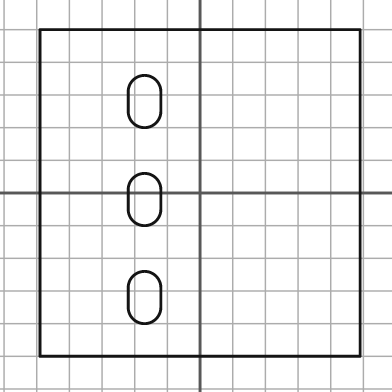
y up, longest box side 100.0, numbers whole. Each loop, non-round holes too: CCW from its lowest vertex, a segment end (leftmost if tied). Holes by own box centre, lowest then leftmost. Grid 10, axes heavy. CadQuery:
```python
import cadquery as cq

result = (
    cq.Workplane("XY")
    .moveTo(-49.0, -50.0)
    .lineTo(49.0, -50.0)
    .lineTo(49.0, 50.0)
    .lineTo(-49.0, 50.0)
    .close()
    .moveTo(-22.0, -35.0)
    .threePointArc((-17.0, -40.0), (-12.0, -35.0))
    .lineTo(-12.0, -29.0)
    .threePointArc((-17.0, -24.0), (-22.0, -29.0))
    .close()
    .moveTo(-22.0, -5.0)
    .threePointArc((-17.0, -10.0), (-12.0, -5.0))
    .lineTo(-12.0, 1.0)
    .threePointArc((-17.0, 6.0), (-22.0, 1.0))
    .close()
    .moveTo(-22.0, 25.0)
    .threePointArc((-17.0, 20.0), (-12.0, 25.0))
    .lineTo(-12.0, 31.0)
    .threePointArc((-17.0, 36.0), (-22.0, 31.0))
    .close()
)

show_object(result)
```